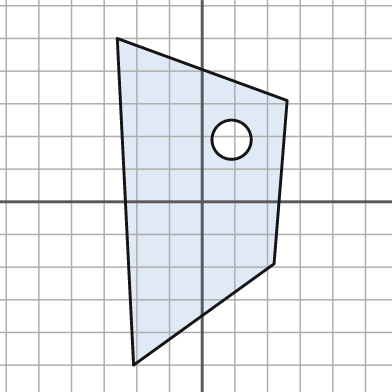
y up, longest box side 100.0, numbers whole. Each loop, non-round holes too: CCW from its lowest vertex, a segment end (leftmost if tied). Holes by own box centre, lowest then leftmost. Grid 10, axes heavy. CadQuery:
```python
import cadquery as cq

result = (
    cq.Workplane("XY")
    .moveTo(-21.0, -50.0)
    .lineTo(22.0, -19.0)
    .lineTo(26.0, 31.0)
    .lineTo(-26.0, 50.0)
    .close()
    .moveTo(9.0, 19.0)
    .circle(6.0)
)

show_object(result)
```